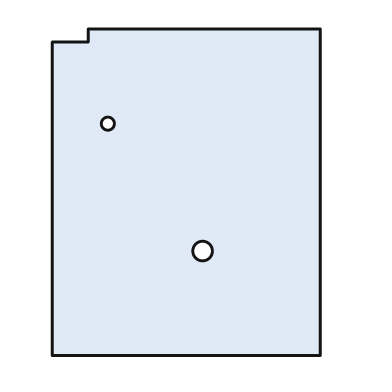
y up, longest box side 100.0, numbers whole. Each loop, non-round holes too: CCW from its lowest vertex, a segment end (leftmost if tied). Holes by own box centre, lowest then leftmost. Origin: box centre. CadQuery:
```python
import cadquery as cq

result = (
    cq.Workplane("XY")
    .moveTo(-41.0, -50.0)
    .lineTo(41.0, -50.0)
    .lineTo(41.0, 50.0)
    .lineTo(-30.0, 50.0)
    .lineTo(-30.0, 46.0)
    .lineTo(-41.0, 46.0)
    .close()
    .moveTo(5.0, -18.0)
    .circle(3.0)
    .moveTo(-24.0, 21.0)
    .circle(2.0)
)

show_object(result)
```